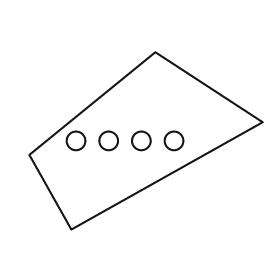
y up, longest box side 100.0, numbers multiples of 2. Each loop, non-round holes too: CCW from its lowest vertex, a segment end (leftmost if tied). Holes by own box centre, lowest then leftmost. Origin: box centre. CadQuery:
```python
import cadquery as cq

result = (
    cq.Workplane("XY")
    .moveTo(-32.0, -38.0)
    .lineTo(50.0, 8.0)
    .lineTo(4.0, 38.0)
    .lineTo(-50.0, -6.0)
    .close()
    .moveTo(-30.0, 0.0)
    .circle(4.0)
    .moveTo(-16.0, 0.0)
    .circle(4.0)
    .moveTo(-2.0, 0.0)
    .circle(4.0)
    .moveTo(12.0, 0.0)
    .circle(4.0)
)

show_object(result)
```